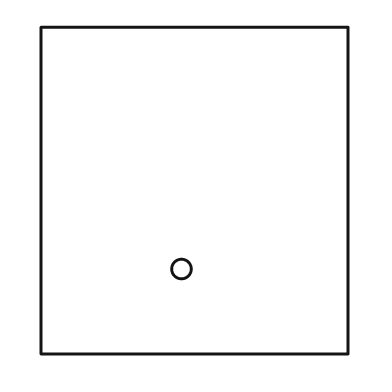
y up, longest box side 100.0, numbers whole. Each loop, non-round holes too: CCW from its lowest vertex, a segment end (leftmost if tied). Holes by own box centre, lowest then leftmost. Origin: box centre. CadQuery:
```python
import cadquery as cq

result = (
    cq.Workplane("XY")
    .moveTo(-47.0, -50.0)
    .lineTo(47.0, -50.0)
    .lineTo(47.0, 50.0)
    .lineTo(-47.0, 50.0)
    .close()
    .moveTo(-4.0, -24.0)
    .circle(3.0)
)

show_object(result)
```